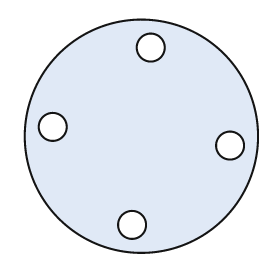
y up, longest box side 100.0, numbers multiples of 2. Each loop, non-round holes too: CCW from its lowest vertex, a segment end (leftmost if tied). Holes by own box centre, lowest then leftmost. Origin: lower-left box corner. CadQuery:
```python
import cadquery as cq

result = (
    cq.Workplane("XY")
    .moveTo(50.0, 50.0)
    .circle(50.0)
    .moveTo(46.0, 12.0)
    .circle(6.0)
    .moveTo(88.0, 46.0)
    .circle(6.0)
    .moveTo(12.0, 54.0)
    .circle(6.0)
    .moveTo(54.0, 88.0)
    .circle(6.0)
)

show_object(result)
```